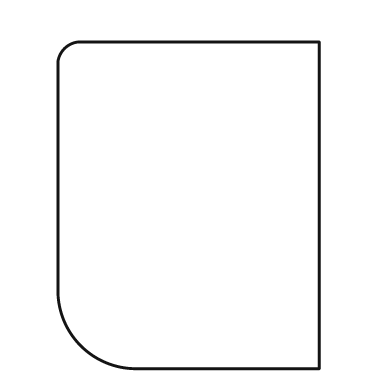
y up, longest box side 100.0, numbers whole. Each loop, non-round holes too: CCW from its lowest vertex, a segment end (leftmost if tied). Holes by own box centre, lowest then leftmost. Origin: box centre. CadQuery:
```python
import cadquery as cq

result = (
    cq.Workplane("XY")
    .moveTo(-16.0, -50.0)
    .lineTo(40.0, -50.0)
    .lineTo(40.0, 50.0)
    .lineTo(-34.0, 50.0)
    .threePointArc((-38.0, 48.0), (-40.0, 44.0))
    .lineTo(-40.0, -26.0)
    .threePointArc((-33.0, -43.0), (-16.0, -50.0))
    .close()
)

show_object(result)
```